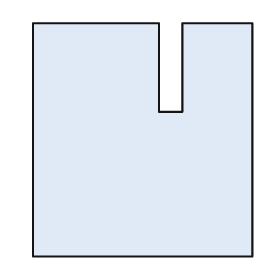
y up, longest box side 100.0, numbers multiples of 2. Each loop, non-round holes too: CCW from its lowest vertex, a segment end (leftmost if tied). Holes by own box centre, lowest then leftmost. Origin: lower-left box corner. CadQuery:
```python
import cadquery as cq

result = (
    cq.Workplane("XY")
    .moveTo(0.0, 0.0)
    .lineTo(94.0, 0.0)
    .lineTo(94.0, 100.0)
    .lineTo(64.0, 100.0)
    .lineTo(64.0, 62.0)
    .lineTo(54.0, 62.0)
    .lineTo(54.0, 100.0)
    .lineTo(0.0, 100.0)
    .close()
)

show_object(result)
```